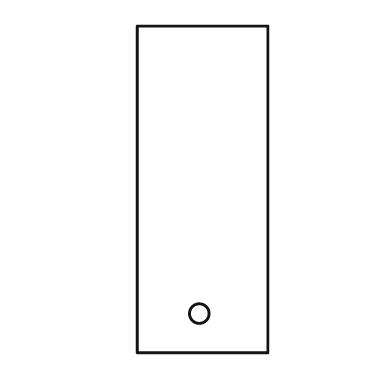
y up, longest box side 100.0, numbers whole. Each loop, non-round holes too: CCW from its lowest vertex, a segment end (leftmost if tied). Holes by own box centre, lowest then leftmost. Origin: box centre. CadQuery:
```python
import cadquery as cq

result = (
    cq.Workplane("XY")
    .moveTo(-20.0, -50.0)
    .lineTo(20.0, -50.0)
    .lineTo(20.0, 50.0)
    .lineTo(-20.0, 50.0)
    .close()
    .moveTo(-1.0, -38.0)
    .circle(3.0)
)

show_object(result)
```